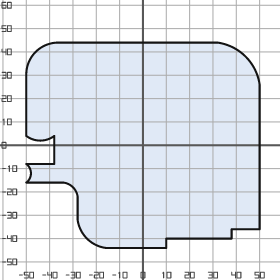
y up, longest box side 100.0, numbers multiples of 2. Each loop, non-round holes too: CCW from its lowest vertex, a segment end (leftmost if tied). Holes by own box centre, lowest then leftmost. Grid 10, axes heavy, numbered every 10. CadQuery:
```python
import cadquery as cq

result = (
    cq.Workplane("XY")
    .moveTo(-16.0, -44.0)
    .lineTo(10.0, -44.0)
    .lineTo(10.0, -40.0)
    .lineTo(38.0, -40.0)
    .lineTo(38.0, -36.0)
    .lineTo(50.0, -36.0)
    .lineTo(50.0, 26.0)
    .threePointArc((44.0, 38.0), (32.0, 44.0))
    .lineTo(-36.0, 44.0)
    .threePointArc((-46.0, 40.0), (-50.0, 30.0))
    .lineTo(-50.0, 4.0)
    .threePointArc((-44.0, 2.0), (-38.0, 4.0))
    .lineTo(-38.0, -8.0)
    .lineTo(-50.0, -8.0)
    .threePointArc((-48.0, -12.0), (-50.0, -16.0))
    .lineTo(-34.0, -16.0)
    .threePointArc((-30.0, -18.0), (-28.0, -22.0))
    .lineTo(-28.0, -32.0)
    .threePointArc((-24.0, -40.0), (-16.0, -44.0))
    .close()
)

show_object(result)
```